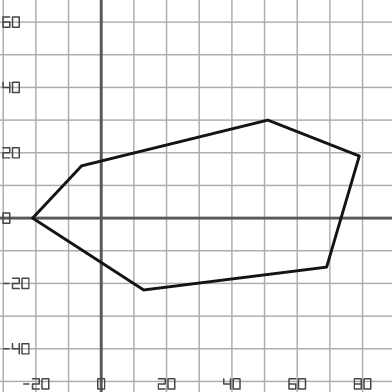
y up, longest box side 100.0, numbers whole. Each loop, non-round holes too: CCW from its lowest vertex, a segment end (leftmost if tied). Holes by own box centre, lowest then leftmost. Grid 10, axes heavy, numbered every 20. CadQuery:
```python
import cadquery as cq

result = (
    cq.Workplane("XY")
    .moveTo(13.0, -22.0)
    .lineTo(69.0, -15.0)
    .lineTo(79.0, 19.0)
    .lineTo(51.0, 30.0)
    .lineTo(-6.0, 16.0)
    .lineTo(-21.0, 0.0)
    .close()
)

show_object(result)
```